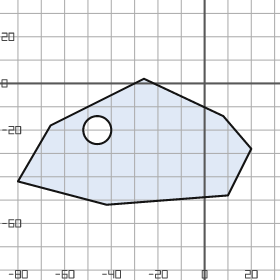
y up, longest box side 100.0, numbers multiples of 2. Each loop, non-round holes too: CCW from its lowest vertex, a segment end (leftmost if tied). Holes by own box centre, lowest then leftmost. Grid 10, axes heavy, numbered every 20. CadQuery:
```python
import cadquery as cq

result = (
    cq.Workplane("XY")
    .moveTo(-42.0, -52.0)
    .lineTo(10.0, -48.0)
    .lineTo(20.0, -28.0)
    .lineTo(8.0, -14.0)
    .lineTo(-26.0, 2.0)
    .lineTo(-66.0, -18.0)
    .lineTo(-80.0, -42.0)
    .close()
    .moveTo(-46.0, -20.0)
    .circle(6.0)
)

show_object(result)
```